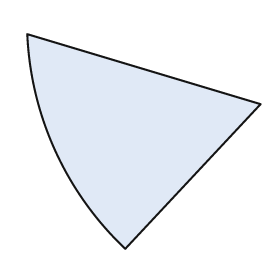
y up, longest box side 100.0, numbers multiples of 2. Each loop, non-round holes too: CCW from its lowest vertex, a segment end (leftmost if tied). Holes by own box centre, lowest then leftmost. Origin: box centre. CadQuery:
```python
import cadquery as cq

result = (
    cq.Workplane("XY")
    .moveTo(-8.0, -46.0)
    .lineTo(50.0, 16.0)
    .lineTo(-50.0, 46.0)
    .threePointArc((-38.0, -4.0), (-8.0, -46.0))
    .close()
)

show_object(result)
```